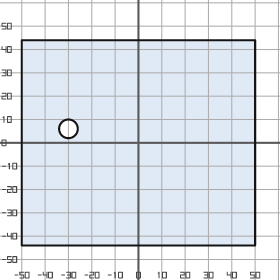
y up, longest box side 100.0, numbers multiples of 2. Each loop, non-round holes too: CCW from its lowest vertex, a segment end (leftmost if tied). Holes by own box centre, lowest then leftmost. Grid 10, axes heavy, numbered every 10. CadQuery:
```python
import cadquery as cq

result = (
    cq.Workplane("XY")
    .moveTo(-50.0, -44.0)
    .lineTo(50.0, -44.0)
    .lineTo(50.0, 44.0)
    .lineTo(-50.0, 44.0)
    .close()
    .moveTo(-30.0, 6.0)
    .circle(4.0)
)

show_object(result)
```